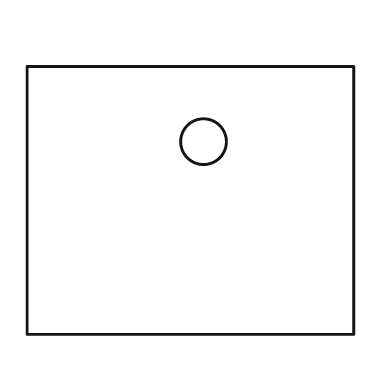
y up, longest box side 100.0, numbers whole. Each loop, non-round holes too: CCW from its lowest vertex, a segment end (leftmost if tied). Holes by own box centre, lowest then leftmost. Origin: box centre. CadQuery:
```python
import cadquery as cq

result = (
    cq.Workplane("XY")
    .moveTo(-50.0, -41.0)
    .lineTo(50.0, -41.0)
    .lineTo(50.0, 41.0)
    .lineTo(-50.0, 41.0)
    .close()
    .moveTo(4.0, 18.0)
    .circle(7.0)
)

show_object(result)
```